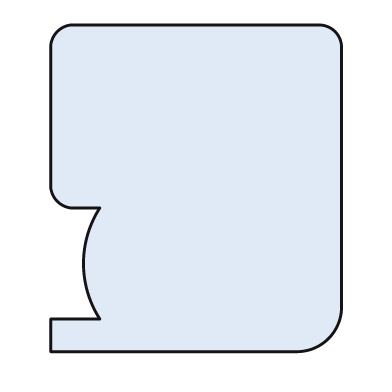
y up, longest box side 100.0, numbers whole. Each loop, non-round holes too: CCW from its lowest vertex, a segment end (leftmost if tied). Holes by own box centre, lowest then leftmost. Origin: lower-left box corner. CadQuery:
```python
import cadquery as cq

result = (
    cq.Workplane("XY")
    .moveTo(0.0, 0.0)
    .lineTo(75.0, 0.0)
    .threePointArc((85.0, 4.0), (89.0, 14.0))
    .lineTo(89.0, 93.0)
    .threePointArc((87.0, 98.0), (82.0, 100.0))
    .lineTo(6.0, 100.0)
    .threePointArc((2.0, 98.0), (0.0, 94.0))
    .lineTo(0.0, 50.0)
    .threePointArc((2.0, 46.0), (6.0, 44.0))
    .lineTo(15.0, 44.0)
    .threePointArc((10.0, 27.0), (15.0, 10.0))
    .lineTo(0.0, 10.0)
    .close()
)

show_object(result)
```